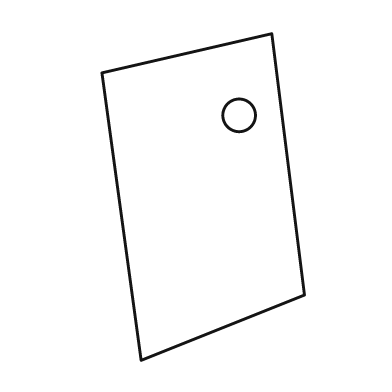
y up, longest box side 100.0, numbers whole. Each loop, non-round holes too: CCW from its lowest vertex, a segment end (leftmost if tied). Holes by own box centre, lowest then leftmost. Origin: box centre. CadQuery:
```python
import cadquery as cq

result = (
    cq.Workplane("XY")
    .moveTo(-19.0, -50.0)
    .lineTo(31.0, -30.0)
    .lineTo(21.0, 50.0)
    .lineTo(-31.0, 38.0)
    .close()
    .moveTo(11.0, 25.0)
    .circle(5.0)
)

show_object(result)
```